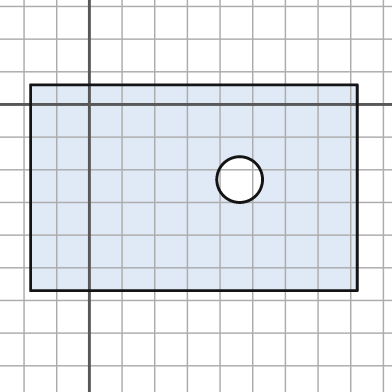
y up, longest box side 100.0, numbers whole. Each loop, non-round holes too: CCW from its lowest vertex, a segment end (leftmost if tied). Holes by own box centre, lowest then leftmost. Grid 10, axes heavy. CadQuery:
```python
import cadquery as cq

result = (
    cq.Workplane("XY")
    .moveTo(-18.0, -57.0)
    .lineTo(82.0, -57.0)
    .lineTo(82.0, 6.0)
    .lineTo(-18.0, 6.0)
    .close()
    .moveTo(46.0, -23.0)
    .circle(7.0)
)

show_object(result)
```